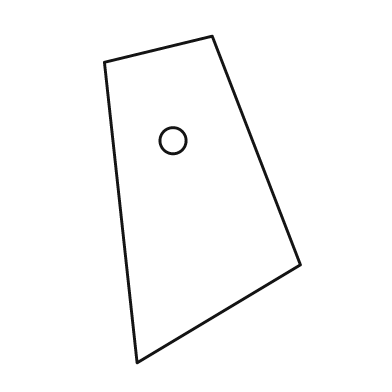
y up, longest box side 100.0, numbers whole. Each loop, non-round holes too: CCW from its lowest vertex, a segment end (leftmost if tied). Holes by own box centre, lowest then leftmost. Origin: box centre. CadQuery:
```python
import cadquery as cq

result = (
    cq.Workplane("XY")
    .moveTo(-20.0, -50.0)
    .lineTo(30.0, -20.0)
    .lineTo(3.0, 50.0)
    .lineTo(-30.0, 42.0)
    .close()
    .moveTo(-9.0, 18.0)
    .circle(4.0)
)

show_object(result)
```